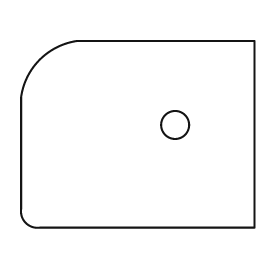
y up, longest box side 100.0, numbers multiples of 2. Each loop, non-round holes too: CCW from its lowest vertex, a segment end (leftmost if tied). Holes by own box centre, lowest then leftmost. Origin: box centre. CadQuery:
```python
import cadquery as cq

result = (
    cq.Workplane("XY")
    .moveTo(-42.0, -40.0)
    .lineTo(50.0, -40.0)
    .lineTo(50.0, 40.0)
    .lineTo(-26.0, 40.0)
    .threePointArc((-42.0, 32.0), (-50.0, 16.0))
    .lineTo(-50.0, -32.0)
    .threePointArc((-48.0, -38.0), (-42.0, -40.0))
    .close()
    .moveTo(16.0, 4.0)
    .circle(6.0)
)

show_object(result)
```